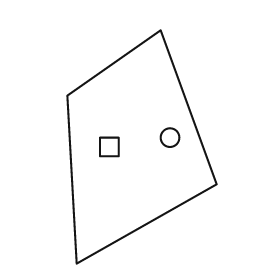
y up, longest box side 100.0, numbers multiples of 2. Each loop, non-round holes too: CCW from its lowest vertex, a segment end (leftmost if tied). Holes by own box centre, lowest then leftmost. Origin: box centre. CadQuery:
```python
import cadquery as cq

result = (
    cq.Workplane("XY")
    .moveTo(-28.0, -50.0)
    .lineTo(32.0, -16.0)
    .lineTo(8.0, 50.0)
    .lineTo(-32.0, 22.0)
    .close()
    .moveTo(-18.0, -4.0)
    .lineTo(-10.0, -4.0)
    .lineTo(-10.0, 4.0)
    .lineTo(-18.0, 4.0)
    .close()
    .moveTo(12.0, 4.0)
    .circle(4.0)
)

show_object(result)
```